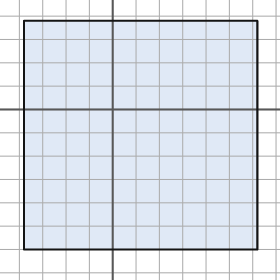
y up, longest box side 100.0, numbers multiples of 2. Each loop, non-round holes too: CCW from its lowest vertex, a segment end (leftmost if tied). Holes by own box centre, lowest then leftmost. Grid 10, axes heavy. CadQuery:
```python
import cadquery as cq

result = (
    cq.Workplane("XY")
    .moveTo(-38.0, -60.0)
    .lineTo(62.0, -60.0)
    .lineTo(62.0, 38.0)
    .lineTo(-38.0, 38.0)
    .close()
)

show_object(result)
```